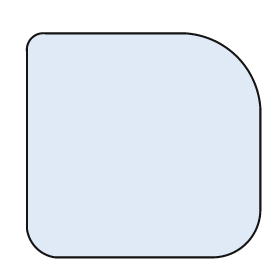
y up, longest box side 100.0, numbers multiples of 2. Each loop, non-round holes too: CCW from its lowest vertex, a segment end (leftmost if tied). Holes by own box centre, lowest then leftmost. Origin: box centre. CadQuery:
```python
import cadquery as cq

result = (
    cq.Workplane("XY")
    .moveTo(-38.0, -48.0)
    .lineTo(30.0, -48.0)
    .threePointArc((44.0, -42.0), (50.0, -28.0))
    .lineTo(50.0, 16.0)
    .threePointArc((40.0, 38.0), (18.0, 48.0))
    .lineTo(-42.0, 48.0)
    .threePointArc((-48.0, 46.0), (-50.0, 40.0))
    .lineTo(-50.0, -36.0)
    .threePointArc((-46.0, -44.0), (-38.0, -48.0))
    .close()
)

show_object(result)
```